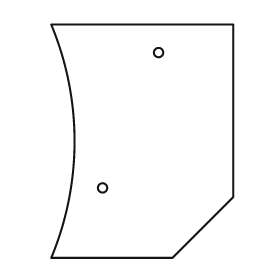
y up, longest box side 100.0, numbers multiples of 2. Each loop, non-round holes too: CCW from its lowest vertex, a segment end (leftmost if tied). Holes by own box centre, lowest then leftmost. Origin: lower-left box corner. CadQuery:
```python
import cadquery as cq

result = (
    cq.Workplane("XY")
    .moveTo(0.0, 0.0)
    .lineTo(52.0, 0.0)
    .lineTo(78.0, 26.0)
    .lineTo(78.0, 100.0)
    .lineTo(0.0, 100.0)
    .threePointArc((10.0, 50.0), (0.0, 0.0))
    .close()
    .moveTo(22.0, 30.0)
    .circle(2.0)
    .moveTo(46.0, 88.0)
    .circle(2.0)
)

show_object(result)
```